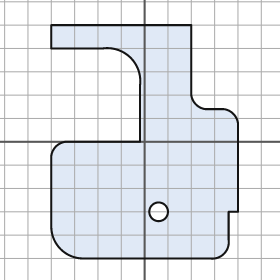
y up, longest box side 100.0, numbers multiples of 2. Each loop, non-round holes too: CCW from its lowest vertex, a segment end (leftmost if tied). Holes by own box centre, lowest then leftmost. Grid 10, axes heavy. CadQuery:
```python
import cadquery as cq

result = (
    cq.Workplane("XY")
    .moveTo(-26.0, -50.0)
    .lineTo(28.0, -50.0)
    .threePointArc((34.0, -48.0), (36.0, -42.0))
    .lineTo(36.0, -30.0)
    .lineTo(40.0, -30.0)
    .lineTo(40.0, 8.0)
    .threePointArc((38.0, 12.0), (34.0, 14.0))
    .lineTo(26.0, 14.0)
    .threePointArc((22.0, 16.0), (20.0, 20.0))
    .lineTo(20.0, 50.0)
    .lineTo(-40.0, 50.0)
    .lineTo(-40.0, 40.0)
    .lineTo(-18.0, 40.0)
    .threePointArc((-6.0, 36.0), (-2.0, 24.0))
    .lineTo(-2.0, 0.0)
    .lineTo(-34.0, 0.0)
    .threePointArc((-38.0, -2.0), (-40.0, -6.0))
    .lineTo(-40.0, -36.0)
    .threePointArc((-36.0, -46.0), (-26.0, -50.0))
    .close()
    .moveTo(6.0, -30.0)
    .circle(4.0)
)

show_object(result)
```